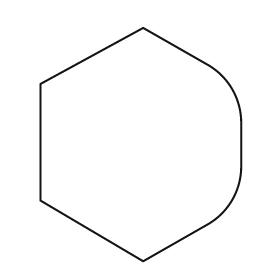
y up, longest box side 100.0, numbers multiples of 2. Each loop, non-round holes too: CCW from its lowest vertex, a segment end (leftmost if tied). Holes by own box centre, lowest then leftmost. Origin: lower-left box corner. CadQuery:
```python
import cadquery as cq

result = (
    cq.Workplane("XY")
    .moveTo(44.0, 0.0)
    .lineTo(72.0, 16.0)
    .threePointArc((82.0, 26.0), (86.0, 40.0))
    .lineTo(86.0, 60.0)
    .threePointArc((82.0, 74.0), (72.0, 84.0))
    .lineTo(44.0, 100.0)
    .lineTo(0.0, 76.0)
    .lineTo(0.0, 26.0)
    .close()
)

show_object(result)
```